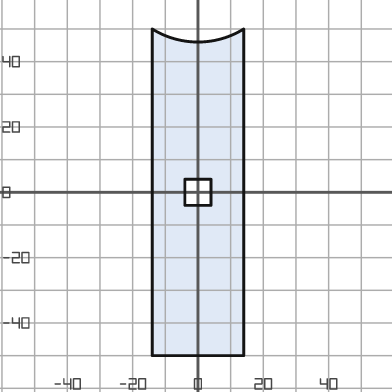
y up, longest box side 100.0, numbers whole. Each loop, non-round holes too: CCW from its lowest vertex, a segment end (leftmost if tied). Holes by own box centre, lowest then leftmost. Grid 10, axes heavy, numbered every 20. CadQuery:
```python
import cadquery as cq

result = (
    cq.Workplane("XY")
    .moveTo(-14.0, -50.0)
    .lineTo(14.0, -50.0)
    .lineTo(14.0, 50.0)
    .threePointArc((0.0, 46.0), (-14.0, 50.0))
    .close()
    .moveTo(-4.0, -4.0)
    .lineTo(4.0, -4.0)
    .lineTo(4.0, 4.0)
    .lineTo(-4.0, 4.0)
    .close()
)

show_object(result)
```